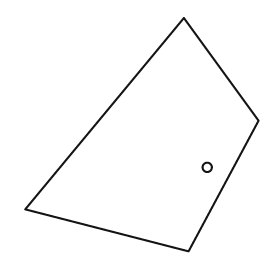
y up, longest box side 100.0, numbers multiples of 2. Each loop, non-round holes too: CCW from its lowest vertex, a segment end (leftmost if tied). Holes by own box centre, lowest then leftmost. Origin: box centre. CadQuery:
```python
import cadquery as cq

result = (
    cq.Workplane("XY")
    .moveTo(20.0, -50.0)
    .lineTo(50.0, 6.0)
    .lineTo(18.0, 50.0)
    .lineTo(-50.0, -32.0)
    .close()
    .moveTo(28.0, -14.0)
    .circle(2.0)
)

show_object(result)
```